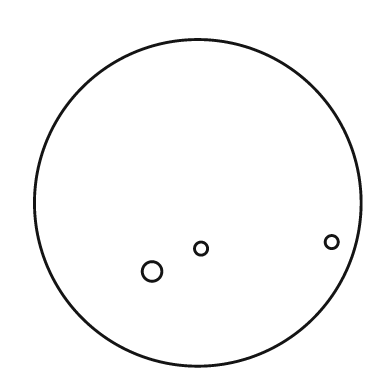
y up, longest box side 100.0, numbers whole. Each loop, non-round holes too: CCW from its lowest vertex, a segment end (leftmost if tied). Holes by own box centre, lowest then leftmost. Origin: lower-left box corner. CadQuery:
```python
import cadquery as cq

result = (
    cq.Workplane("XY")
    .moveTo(50.0, 50.0)
    .circle(50.0)
    .moveTo(36.0, 29.0)
    .circle(3.0)
    .moveTo(51.0, 36.0)
    .circle(2.0)
    .moveTo(91.0, 38.0)
    .circle(2.0)
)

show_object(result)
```